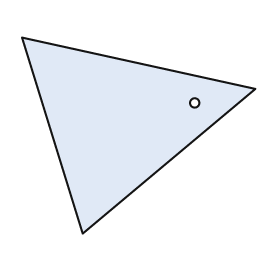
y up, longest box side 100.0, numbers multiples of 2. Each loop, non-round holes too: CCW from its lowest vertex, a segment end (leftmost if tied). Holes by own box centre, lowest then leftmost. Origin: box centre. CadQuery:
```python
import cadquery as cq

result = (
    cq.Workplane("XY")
    .moveTo(-24.0, -42.0)
    .lineTo(50.0, 20.0)
    .lineTo(-50.0, 42.0)
    .close()
    .moveTo(24.0, 14.0)
    .circle(2.0)
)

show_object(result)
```